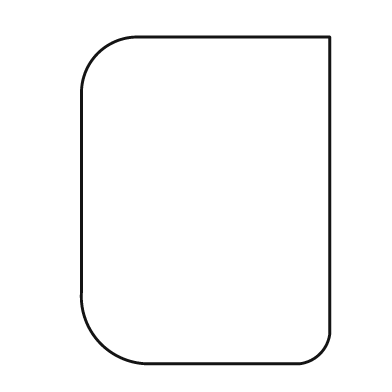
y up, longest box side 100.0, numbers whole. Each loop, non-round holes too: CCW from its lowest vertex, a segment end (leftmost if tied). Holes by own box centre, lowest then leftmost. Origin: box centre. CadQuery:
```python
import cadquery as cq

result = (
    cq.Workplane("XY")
    .moveTo(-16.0, -50.0)
    .lineTo(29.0, -50.0)
    .threePointArc((35.0, -47.0), (38.0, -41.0))
    .lineTo(38.0, 50.0)
    .lineTo(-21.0, 50.0)
    .threePointArc((-33.0, 45.0), (-38.0, 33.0))
    .lineTo(-38.0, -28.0)
    .threePointArc((-32.0, -44.0), (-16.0, -50.0))
    .close()
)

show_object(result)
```